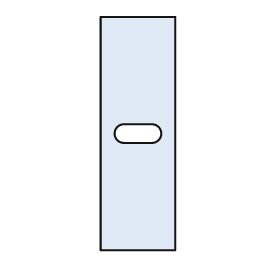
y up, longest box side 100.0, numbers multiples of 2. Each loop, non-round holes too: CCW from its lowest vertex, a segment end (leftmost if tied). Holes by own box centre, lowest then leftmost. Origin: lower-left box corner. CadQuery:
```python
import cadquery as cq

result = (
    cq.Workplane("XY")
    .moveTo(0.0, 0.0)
    .lineTo(32.0, 0.0)
    .lineTo(32.0, 100.0)
    .lineTo(0.0, 100.0)
    .close()
    .moveTo(10.0, 46.0)
    .lineTo(22.0, 46.0)
    .threePointArc((26.0, 50.0), (22.0, 54.0))
    .lineTo(10.0, 54.0)
    .threePointArc((6.0, 50.0), (10.0, 46.0))
    .close()
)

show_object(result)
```